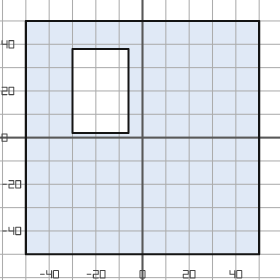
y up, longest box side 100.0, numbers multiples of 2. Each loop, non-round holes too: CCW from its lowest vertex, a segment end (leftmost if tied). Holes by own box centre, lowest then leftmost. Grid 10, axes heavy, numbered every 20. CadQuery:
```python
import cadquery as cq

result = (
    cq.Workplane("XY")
    .moveTo(-50.0, -50.0)
    .lineTo(50.0, -50.0)
    .lineTo(50.0, 50.0)
    .lineTo(-50.0, 50.0)
    .close()
    .moveTo(-30.0, 2.0)
    .lineTo(-6.0, 2.0)
    .lineTo(-6.0, 38.0)
    .lineTo(-30.0, 38.0)
    .close()
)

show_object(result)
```